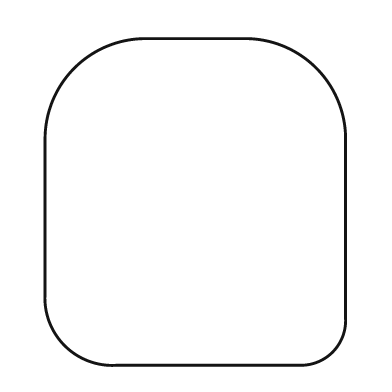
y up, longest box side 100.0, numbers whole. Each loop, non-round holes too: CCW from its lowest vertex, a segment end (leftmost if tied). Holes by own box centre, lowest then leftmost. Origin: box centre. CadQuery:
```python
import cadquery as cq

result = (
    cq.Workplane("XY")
    .moveTo(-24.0, -50.0)
    .lineTo(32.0, -50.0)
    .threePointArc((42.0, -46.0), (46.0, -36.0))
    .lineTo(46.0, 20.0)
    .threePointArc((37.0, 41.0), (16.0, 50.0))
    .lineTo(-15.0, 50.0)
    .threePointArc((-37.0, 41.0), (-46.0, 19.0))
    .lineTo(-46.0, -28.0)
    .threePointArc((-40.0, -44.0), (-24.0, -50.0))
    .close()
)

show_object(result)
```